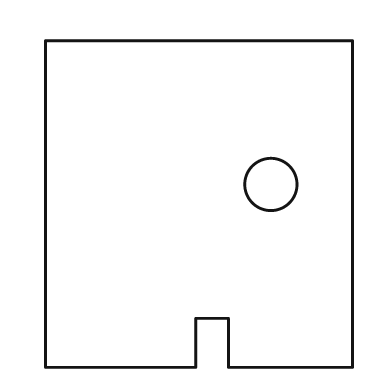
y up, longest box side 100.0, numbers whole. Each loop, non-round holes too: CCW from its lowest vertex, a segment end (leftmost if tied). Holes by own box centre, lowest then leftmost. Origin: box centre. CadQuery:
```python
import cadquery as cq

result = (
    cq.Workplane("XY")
    .moveTo(-47.0, -50.0)
    .lineTo(-1.0, -50.0)
    .lineTo(-1.0, -35.0)
    .lineTo(9.0, -35.0)
    .lineTo(9.0, -50.0)
    .lineTo(47.0, -50.0)
    .lineTo(47.0, 50.0)
    .lineTo(-47.0, 50.0)
    .close()
    .moveTo(22.0, 6.0)
    .circle(8.0)
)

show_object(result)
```